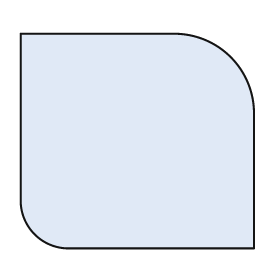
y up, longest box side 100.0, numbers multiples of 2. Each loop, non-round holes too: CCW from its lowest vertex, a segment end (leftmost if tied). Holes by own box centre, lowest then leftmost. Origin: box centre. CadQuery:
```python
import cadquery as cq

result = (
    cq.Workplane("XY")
    .moveTo(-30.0, -46.0)
    .lineTo(50.0, -46.0)
    .lineTo(50.0, 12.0)
    .threePointArc((40.0, 36.0), (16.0, 46.0))
    .lineTo(-50.0, 46.0)
    .lineTo(-50.0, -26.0)
    .threePointArc((-44.0, -40.0), (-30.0, -46.0))
    .close()
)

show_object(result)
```